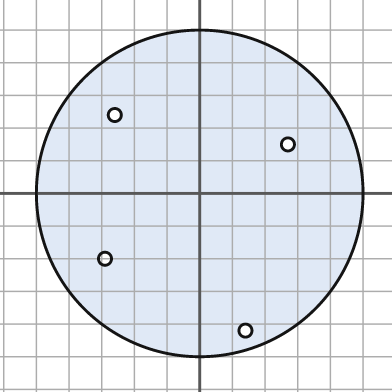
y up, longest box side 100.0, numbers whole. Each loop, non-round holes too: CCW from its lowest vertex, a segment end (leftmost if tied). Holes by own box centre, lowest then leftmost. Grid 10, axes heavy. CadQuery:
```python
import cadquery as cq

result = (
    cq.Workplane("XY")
    .moveTo(0.0, 0.0)
    .circle(50.0)
    .moveTo(14.0, -42.0)
    .circle(2.0)
    .moveTo(-29.0, -20.0)
    .circle(2.0)
    .moveTo(27.0, 15.0)
    .circle(2.0)
    .moveTo(-26.0, 24.0)
    .circle(2.0)
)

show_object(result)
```